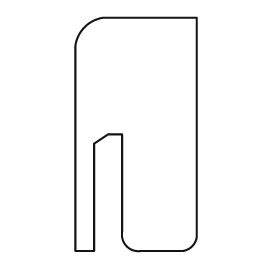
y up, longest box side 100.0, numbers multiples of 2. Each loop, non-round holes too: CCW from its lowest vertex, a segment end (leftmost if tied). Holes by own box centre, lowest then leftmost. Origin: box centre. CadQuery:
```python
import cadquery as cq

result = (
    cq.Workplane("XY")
    .moveTo(-26.0, -50.0)
    .lineTo(-18.0, -50.0)
    .lineTo(-18.0, -4.0)
    .lineTo(-12.0, 0.0)
    .lineTo(-6.0, 0.0)
    .lineTo(-6.0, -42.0)
    .threePointArc((-4.0, -48.0), (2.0, -50.0))
    .lineTo(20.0, -50.0)
    .threePointArc((24.0, -48.0), (26.0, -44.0))
    .lineTo(26.0, 50.0)
    .lineTo(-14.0, 50.0)
    .threePointArc((-22.0, 46.0), (-26.0, 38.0))
    .close()
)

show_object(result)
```